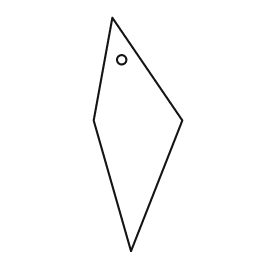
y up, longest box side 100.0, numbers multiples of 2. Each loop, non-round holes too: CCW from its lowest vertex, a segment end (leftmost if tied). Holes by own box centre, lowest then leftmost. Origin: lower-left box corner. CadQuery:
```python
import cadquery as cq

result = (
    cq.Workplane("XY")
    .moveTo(16.0, 0.0)
    .lineTo(38.0, 56.0)
    .lineTo(8.0, 100.0)
    .lineTo(0.0, 56.0)
    .close()
    .moveTo(12.0, 82.0)
    .circle(2.0)
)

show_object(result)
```